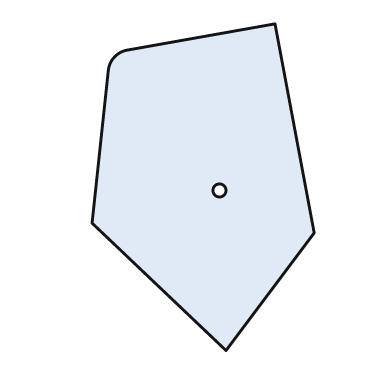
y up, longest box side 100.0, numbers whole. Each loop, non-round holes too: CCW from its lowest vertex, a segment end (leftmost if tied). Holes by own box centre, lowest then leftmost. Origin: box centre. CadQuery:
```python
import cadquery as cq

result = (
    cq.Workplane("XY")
    .moveTo(7.0, -50.0)
    .lineTo(34.0, -14.0)
    .lineTo(22.0, 50.0)
    .lineTo(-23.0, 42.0)
    .threePointArc((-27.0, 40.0), (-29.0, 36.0))
    .lineTo(-34.0, -11.0)
    .close()
    .moveTo(5.0, -1.0)
    .circle(2.0)
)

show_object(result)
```